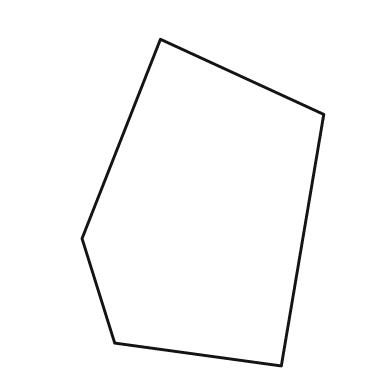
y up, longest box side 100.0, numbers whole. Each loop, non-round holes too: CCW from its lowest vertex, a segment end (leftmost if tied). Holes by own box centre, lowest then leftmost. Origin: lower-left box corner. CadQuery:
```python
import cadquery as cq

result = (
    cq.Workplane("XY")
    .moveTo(61.0, 0.0)
    .lineTo(74.0, 77.0)
    .lineTo(24.0, 100.0)
    .lineTo(0.0, 39.0)
    .lineTo(10.0, 7.0)
    .close()
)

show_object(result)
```